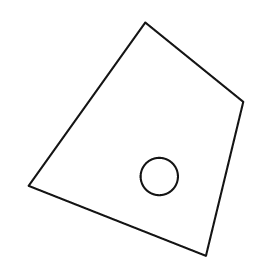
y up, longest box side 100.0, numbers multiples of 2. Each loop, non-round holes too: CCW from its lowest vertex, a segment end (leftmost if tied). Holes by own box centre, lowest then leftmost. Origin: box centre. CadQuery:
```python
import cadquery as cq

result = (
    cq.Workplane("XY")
    .moveTo(30.0, -50.0)
    .lineTo(46.0, 16.0)
    .lineTo(4.0, 50.0)
    .lineTo(-46.0, -20.0)
    .close()
    .moveTo(10.0, -16.0)
    .circle(8.0)
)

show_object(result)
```